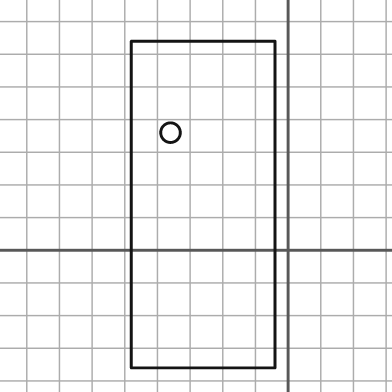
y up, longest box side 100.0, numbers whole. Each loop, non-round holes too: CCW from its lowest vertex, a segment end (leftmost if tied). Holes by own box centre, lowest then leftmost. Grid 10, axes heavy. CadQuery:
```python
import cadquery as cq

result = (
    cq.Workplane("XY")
    .moveTo(-48.0, -36.0)
    .lineTo(-4.0, -36.0)
    .lineTo(-4.0, 64.0)
    .lineTo(-48.0, 64.0)
    .close()
    .moveTo(-36.0, 36.0)
    .circle(3.0)
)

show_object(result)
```